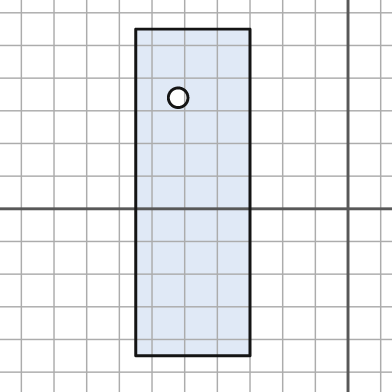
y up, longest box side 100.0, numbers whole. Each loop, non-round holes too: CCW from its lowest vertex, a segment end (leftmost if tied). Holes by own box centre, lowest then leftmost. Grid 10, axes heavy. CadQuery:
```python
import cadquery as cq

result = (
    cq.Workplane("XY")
    .moveTo(-65.0, -45.0)
    .lineTo(-30.0, -45.0)
    .lineTo(-30.0, 55.0)
    .lineTo(-65.0, 55.0)
    .close()
    .moveTo(-52.0, 34.0)
    .circle(3.0)
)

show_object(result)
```